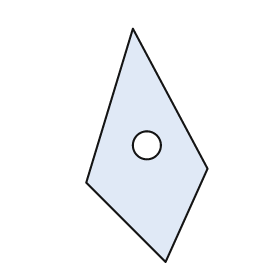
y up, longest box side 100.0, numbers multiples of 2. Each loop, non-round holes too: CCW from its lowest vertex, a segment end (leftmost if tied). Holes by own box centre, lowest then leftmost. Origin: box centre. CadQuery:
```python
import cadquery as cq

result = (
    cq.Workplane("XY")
    .moveTo(8.0, -50.0)
    .lineTo(26.0, -10.0)
    .lineTo(-6.0, 50.0)
    .lineTo(-26.0, -16.0)
    .close()
    .moveTo(0.0, 0.0)
    .circle(6.0)
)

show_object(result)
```